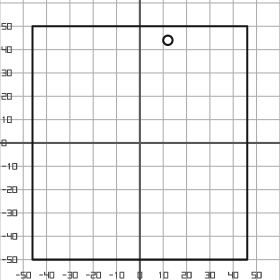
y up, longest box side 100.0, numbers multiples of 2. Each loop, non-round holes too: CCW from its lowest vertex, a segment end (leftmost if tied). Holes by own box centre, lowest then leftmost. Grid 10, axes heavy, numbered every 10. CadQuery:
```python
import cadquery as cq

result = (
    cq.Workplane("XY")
    .moveTo(-46.0, -50.0)
    .lineTo(46.0, -50.0)
    .lineTo(46.0, 50.0)
    .lineTo(-46.0, 50.0)
    .close()
    .moveTo(12.0, 44.0)
    .circle(2.0)
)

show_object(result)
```